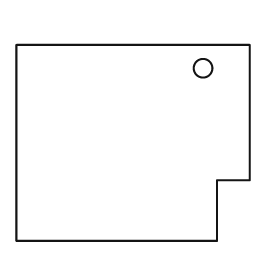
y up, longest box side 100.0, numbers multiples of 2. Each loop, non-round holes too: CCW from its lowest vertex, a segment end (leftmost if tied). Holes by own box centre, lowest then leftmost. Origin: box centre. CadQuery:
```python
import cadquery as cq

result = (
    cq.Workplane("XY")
    .moveTo(-50.0, -42.0)
    .lineTo(36.0, -42.0)
    .lineTo(36.0, -16.0)
    .lineTo(50.0, -16.0)
    .lineTo(50.0, 42.0)
    .lineTo(-50.0, 42.0)
    .close()
    .moveTo(30.0, 32.0)
    .circle(4.0)
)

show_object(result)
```